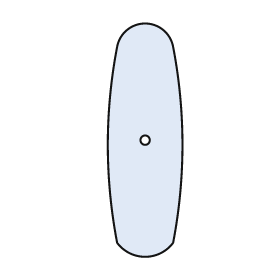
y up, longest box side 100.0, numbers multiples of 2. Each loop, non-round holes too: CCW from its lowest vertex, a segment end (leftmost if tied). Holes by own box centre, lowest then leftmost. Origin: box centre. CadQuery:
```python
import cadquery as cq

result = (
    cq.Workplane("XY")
    .moveTo(-12.0, -44.0)
    .threePointArc((0.0, -50.0), (12.0, -44.0))
    .threePointArc((16.0, -2.0), (12.0, 40.0))
    .threePointArc((0.0, 50.0), (-12.0, 40.0))
    .threePointArc((-16.0, -2.0), (-12.0, -44.0))
    .close()
    .moveTo(0.0, 0.0)
    .circle(2.0)
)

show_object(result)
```